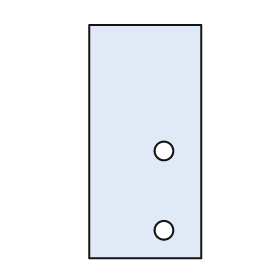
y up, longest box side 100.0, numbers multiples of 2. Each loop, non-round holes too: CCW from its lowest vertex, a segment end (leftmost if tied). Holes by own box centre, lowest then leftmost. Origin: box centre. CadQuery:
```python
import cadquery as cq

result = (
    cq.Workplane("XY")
    .moveTo(-24.0, -50.0)
    .lineTo(24.0, -50.0)
    .lineTo(24.0, 50.0)
    .lineTo(-24.0, 50.0)
    .close()
    .moveTo(8.0, -38.0)
    .circle(4.0)
    .moveTo(8.0, -4.0)
    .circle(4.0)
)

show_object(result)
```